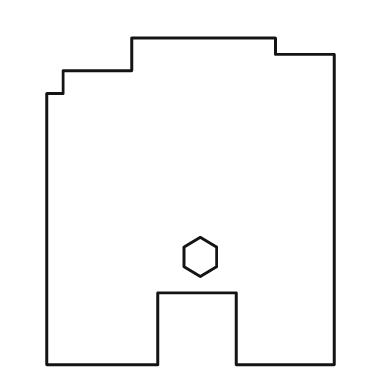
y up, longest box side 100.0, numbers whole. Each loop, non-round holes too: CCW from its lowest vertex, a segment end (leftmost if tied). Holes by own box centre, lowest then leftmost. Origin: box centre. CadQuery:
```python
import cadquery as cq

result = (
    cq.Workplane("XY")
    .moveTo(-44.0, -50.0)
    .lineTo(-10.0, -50.0)
    .lineTo(-10.0, -28.0)
    .lineTo(14.0, -28.0)
    .lineTo(14.0, -50.0)
    .lineTo(44.0, -50.0)
    .lineTo(44.0, 45.0)
    .lineTo(26.0, 45.0)
    .lineTo(26.0, 50.0)
    .lineTo(-18.0, 50.0)
    .lineTo(-18.0, 40.0)
    .lineTo(-39.0, 40.0)
    .lineTo(-39.0, 33.0)
    .lineTo(-44.0, 33.0)
    .close()
    .moveTo(3.0, -23.0)
    .lineTo(8.0, -20.0)
    .lineTo(8.0, -14.0)
    .lineTo(3.0, -11.0)
    .lineTo(-2.0, -14.0)
    .lineTo(-2.0, -20.0)
    .close()
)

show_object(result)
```